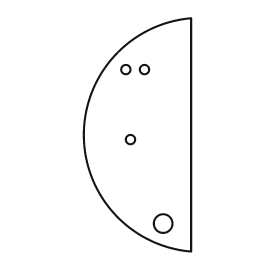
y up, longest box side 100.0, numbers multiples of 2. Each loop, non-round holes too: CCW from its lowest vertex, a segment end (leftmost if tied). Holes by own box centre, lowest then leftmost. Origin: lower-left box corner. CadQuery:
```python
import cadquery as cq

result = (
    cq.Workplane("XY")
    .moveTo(46.0, 0.0)
    .lineTo(46.0, 100.0)
    .threePointArc((0.0, 50.0), (46.0, 0.0))
    .close()
    .moveTo(34.0, 12.0)
    .circle(4.0)
    .moveTo(20.0, 48.0)
    .circle(2.0)
    .moveTo(18.0, 78.0)
    .circle(2.0)
    .moveTo(26.0, 78.0)
    .circle(2.0)
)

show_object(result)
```